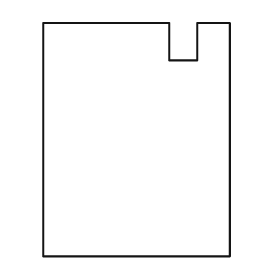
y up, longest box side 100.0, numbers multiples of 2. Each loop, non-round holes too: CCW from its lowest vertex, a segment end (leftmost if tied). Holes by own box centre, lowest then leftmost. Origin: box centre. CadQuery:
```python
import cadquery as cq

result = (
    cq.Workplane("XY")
    .moveTo(-40.0, -50.0)
    .lineTo(40.0, -50.0)
    .lineTo(40.0, 50.0)
    .lineTo(26.0, 50.0)
    .lineTo(26.0, 34.0)
    .lineTo(14.0, 34.0)
    .lineTo(14.0, 50.0)
    .lineTo(-40.0, 50.0)
    .close()
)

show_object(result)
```